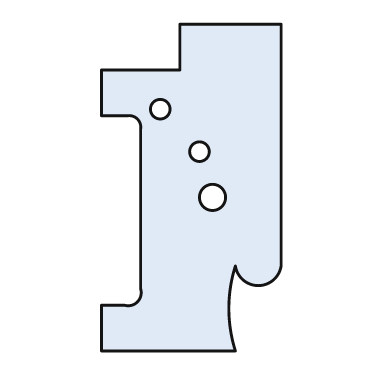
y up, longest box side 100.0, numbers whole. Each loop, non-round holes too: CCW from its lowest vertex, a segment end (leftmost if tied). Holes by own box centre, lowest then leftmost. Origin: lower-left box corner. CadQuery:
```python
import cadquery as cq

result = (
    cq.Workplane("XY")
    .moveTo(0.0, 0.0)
    .lineTo(41.0, 0.0)
    .threePointArc((39.0, 13.0), (41.0, 26.0))
    .threePointArc((48.0, 20.0), (55.0, 26.0))
    .lineTo(55.0, 100.0)
    .lineTo(24.0, 100.0)
    .lineTo(24.0, 86.0)
    .lineTo(0.0, 86.0)
    .lineTo(0.0, 72.0)
    .lineTo(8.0, 72.0)
    .threePointArc((11.0, 71.0), (12.0, 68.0))
    .lineTo(12.0, 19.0)
    .threePointArc((11.0, 15.0), (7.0, 14.0))
    .lineTo(0.0, 14.0)
    .close()
    .moveTo(34.0, 47.0)
    .circle(4.0)
    .moveTo(30.0, 61.0)
    .circle(3.0)
    .moveTo(18.0, 74.0)
    .circle(3.0)
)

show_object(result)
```